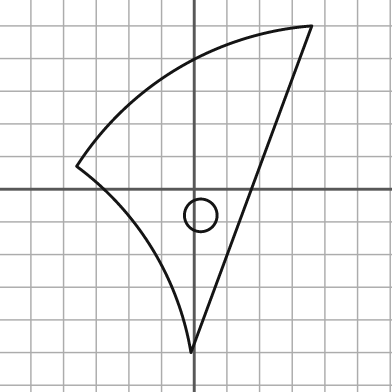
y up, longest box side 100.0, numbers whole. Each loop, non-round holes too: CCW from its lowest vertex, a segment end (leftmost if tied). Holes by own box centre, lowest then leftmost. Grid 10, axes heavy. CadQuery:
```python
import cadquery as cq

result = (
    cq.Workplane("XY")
    .moveTo(-1.0, -50.0)
    .lineTo(36.0, 50.0)
    .threePointArc((-5.0, 37.0), (-36.0, 7.0))
    .threePointArc((-13.0, -18.0), (-1.0, -50.0))
    .close()
    .moveTo(2.0, -8.0)
    .circle(5.0)
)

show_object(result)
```